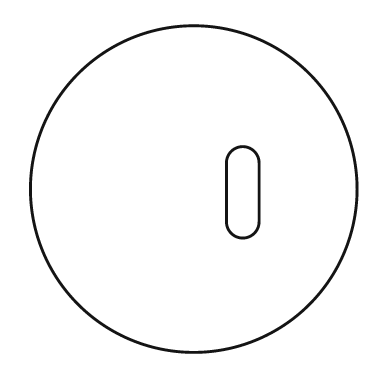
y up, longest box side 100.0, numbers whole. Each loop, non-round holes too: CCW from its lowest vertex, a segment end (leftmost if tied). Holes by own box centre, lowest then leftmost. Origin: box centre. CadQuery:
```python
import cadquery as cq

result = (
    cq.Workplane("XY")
    .moveTo(0.0, 0.0)
    .circle(50.0)
    .moveTo(10.0, -10.0)
    .threePointArc((15.0, -15.0), (20.0, -10.0))
    .lineTo(20.0, 8.0)
    .threePointArc((15.0, 13.0), (10.0, 8.0))
    .close()
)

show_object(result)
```